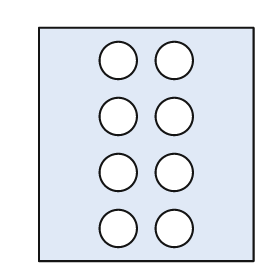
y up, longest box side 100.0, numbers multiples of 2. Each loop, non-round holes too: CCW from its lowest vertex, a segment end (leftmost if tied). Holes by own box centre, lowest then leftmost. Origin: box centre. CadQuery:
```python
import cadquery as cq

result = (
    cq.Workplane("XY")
    .moveTo(-46.0, -50.0)
    .lineTo(46.0, -50.0)
    .lineTo(46.0, 50.0)
    .lineTo(-46.0, 50.0)
    .close()
    .moveTo(-12.0, -36.0)
    .circle(8.0)
    .moveTo(12.0, -36.0)
    .circle(8.0)
    .moveTo(-12.0, -12.0)
    .circle(8.0)
    .moveTo(12.0, -12.0)
    .circle(8.0)
    .moveTo(-12.0, 12.0)
    .circle(8.0)
    .moveTo(12.0, 12.0)
    .circle(8.0)
    .moveTo(-12.0, 36.0)
    .circle(8.0)
    .moveTo(12.0, 36.0)
    .circle(8.0)
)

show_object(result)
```